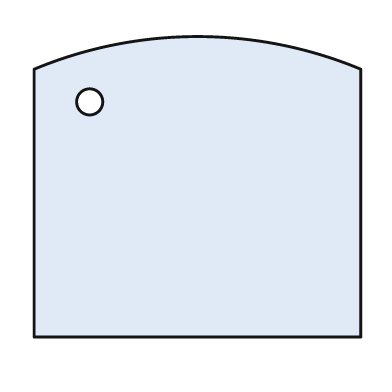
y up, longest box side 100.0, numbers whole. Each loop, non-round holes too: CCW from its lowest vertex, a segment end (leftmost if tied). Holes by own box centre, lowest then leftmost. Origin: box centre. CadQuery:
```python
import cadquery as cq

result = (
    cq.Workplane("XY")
    .moveTo(-50.0, -46.0)
    .lineTo(50.0, -46.0)
    .lineTo(50.0, 36.0)
    .threePointArc((0.0, 46.0), (-50.0, 36.0))
    .close()
    .moveTo(-33.0, 26.0)
    .circle(4.0)
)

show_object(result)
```